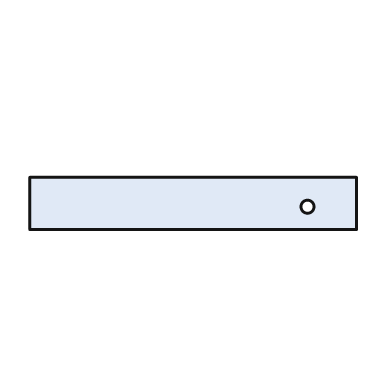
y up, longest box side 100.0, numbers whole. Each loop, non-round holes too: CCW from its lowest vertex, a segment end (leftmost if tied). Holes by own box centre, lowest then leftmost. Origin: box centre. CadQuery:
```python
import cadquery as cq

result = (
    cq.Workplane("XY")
    .moveTo(-50.0, -8.0)
    .lineTo(50.0, -8.0)
    .lineTo(50.0, 8.0)
    .lineTo(-50.0, 8.0)
    .close()
    .moveTo(35.0, -1.0)
    .circle(2.0)
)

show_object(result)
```